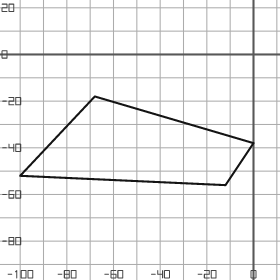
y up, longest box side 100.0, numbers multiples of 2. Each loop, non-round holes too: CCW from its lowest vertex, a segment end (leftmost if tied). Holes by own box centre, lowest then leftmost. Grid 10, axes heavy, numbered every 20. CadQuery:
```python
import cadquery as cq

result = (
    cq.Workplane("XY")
    .moveTo(-12.0, -56.0)
    .lineTo(0.0, -38.0)
    .lineTo(-68.0, -18.0)
    .lineTo(-100.0, -52.0)
    .close()
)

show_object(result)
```